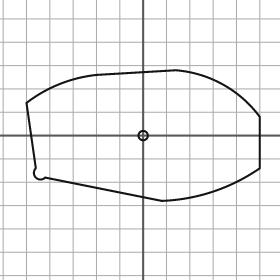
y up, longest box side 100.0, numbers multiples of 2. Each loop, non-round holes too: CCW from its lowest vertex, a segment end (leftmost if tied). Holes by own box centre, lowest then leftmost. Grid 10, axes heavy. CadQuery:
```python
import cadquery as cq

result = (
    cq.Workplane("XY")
    .moveTo(8.0, -28.0)
    .threePointArc((30.0, -24.0), (50.0, -14.0))
    .lineTo(50.0, 8.0)
    .threePointArc((34.0, 22.0), (14.0, 28.0))
    .lineTo(-20.0, 26.0)
    .threePointArc((-36.0, 22.0), (-50.0, 14.0))
    .lineTo(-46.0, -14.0)
    .threePointArc((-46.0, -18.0), (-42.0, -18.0))
    .close()
    .moveTo(0.0, 0.0)
    .circle(2.0)
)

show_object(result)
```